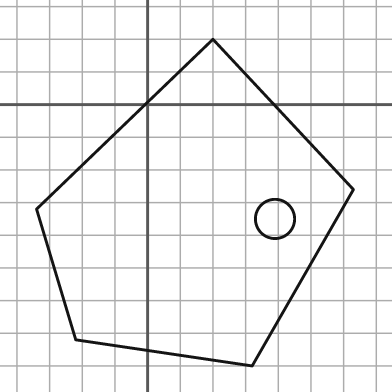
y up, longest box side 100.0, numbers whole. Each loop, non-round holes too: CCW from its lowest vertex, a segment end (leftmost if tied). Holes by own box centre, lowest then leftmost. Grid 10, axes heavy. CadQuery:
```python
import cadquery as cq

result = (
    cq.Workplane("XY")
    .moveTo(32.0, -80.0)
    .lineTo(63.0, -26.0)
    .lineTo(20.0, 20.0)
    .lineTo(-34.0, -32.0)
    .lineTo(-22.0, -72.0)
    .close()
    .moveTo(39.0, -35.0)
    .circle(6.0)
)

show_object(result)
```